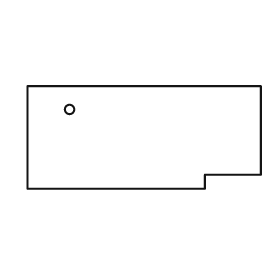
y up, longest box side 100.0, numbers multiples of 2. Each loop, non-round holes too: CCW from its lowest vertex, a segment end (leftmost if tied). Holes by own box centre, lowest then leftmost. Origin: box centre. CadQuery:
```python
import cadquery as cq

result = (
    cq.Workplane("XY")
    .moveTo(-50.0, -22.0)
    .lineTo(26.0, -22.0)
    .lineTo(26.0, -16.0)
    .lineTo(50.0, -16.0)
    .lineTo(50.0, 22.0)
    .lineTo(-50.0, 22.0)
    .close()
    .moveTo(-32.0, 12.0)
    .circle(2.0)
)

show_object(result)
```